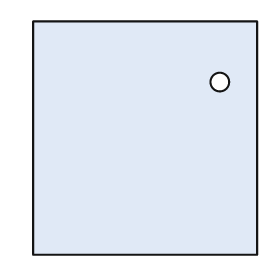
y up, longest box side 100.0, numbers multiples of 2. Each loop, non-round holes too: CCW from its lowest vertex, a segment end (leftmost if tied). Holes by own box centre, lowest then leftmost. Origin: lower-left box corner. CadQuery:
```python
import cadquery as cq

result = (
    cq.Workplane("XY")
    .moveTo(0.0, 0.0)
    .lineTo(96.0, 0.0)
    .lineTo(96.0, 100.0)
    .lineTo(0.0, 100.0)
    .close()
    .moveTo(80.0, 74.0)
    .circle(4.0)
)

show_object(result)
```